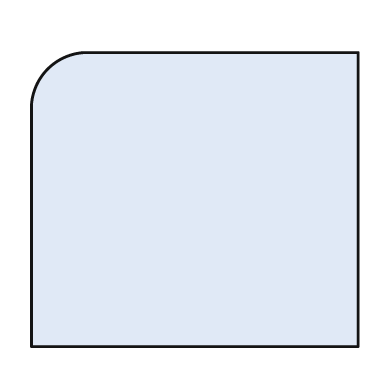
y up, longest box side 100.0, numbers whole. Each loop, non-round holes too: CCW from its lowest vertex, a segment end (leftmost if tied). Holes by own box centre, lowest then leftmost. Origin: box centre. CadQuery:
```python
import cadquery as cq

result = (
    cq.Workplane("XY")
    .moveTo(-50.0, -45.0)
    .lineTo(50.0, -45.0)
    .lineTo(50.0, 45.0)
    .lineTo(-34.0, 45.0)
    .threePointArc((-45.0, 40.0), (-50.0, 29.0))
    .close()
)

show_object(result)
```